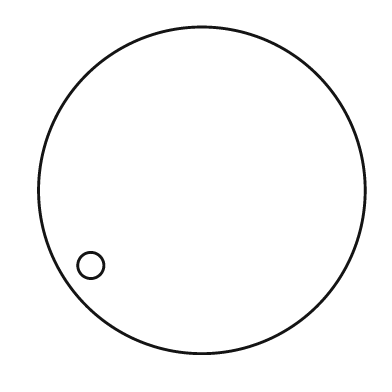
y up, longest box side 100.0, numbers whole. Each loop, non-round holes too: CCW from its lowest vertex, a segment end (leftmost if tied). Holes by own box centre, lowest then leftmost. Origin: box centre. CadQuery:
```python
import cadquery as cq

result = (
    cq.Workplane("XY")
    .moveTo(0.0, 0.0)
    .circle(50.0)
    .moveTo(-34.0, -23.0)
    .circle(4.0)
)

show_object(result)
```